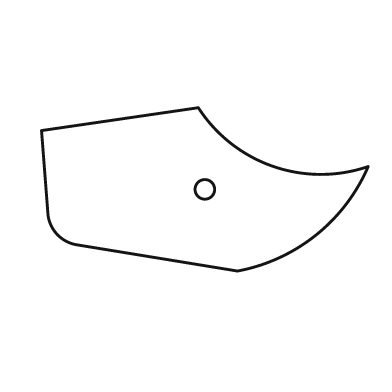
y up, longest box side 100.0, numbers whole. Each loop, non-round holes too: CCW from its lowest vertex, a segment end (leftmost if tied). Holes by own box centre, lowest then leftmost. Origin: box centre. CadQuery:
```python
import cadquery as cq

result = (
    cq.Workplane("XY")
    .moveTo(10.0, -25.0)
    .threePointArc((34.0, -14.0), (50.0, 7.0))
    .threePointArc((21.0, 7.0), (-2.0, 25.0))
    .lineTo(-50.0, 18.0)
    .lineTo(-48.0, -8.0)
    .threePointArc((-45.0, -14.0), (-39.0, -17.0))
    .close()
    .moveTo(0.0, 0.0)
    .circle(3.0)
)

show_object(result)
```